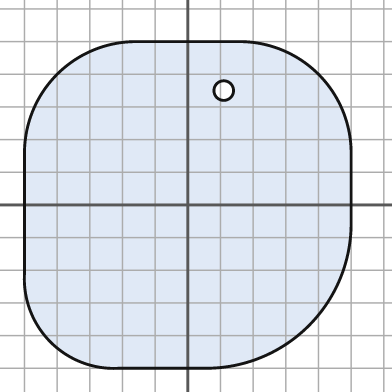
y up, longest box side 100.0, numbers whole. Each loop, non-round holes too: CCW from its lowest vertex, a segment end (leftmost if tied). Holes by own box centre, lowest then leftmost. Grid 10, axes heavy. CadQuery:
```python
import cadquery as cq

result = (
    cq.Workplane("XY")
    .moveTo(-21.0, -50.0)
    .lineTo(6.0, -50.0)
    .threePointArc((37.0, -37.0), (50.0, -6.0))
    .lineTo(50.0, 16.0)
    .threePointArc((40.0, 40.0), (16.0, 50.0))
    .lineTo(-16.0, 50.0)
    .threePointArc((-40.0, 40.0), (-50.0, 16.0))
    .lineTo(-50.0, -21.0)
    .threePointArc((-42.0, -42.0), (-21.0, -50.0))
    .close()
    .moveTo(11.0, 35.0)
    .circle(3.0)
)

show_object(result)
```